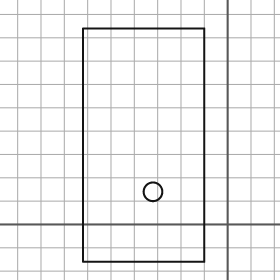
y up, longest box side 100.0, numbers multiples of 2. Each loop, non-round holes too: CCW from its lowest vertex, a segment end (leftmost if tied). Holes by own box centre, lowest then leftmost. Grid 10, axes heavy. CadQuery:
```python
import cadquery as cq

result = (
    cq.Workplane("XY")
    .moveTo(-62.0, -16.0)
    .lineTo(-10.0, -16.0)
    .lineTo(-10.0, 84.0)
    .lineTo(-62.0, 84.0)
    .close()
    .moveTo(-32.0, 14.0)
    .circle(4.0)
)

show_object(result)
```